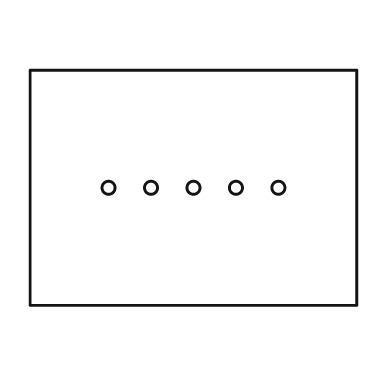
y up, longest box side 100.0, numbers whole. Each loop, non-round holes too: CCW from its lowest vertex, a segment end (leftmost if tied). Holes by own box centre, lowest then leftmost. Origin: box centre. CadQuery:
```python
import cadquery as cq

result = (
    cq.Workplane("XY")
    .moveTo(-50.0, -36.0)
    .lineTo(50.0, -36.0)
    .lineTo(50.0, 36.0)
    .lineTo(-50.0, 36.0)
    .close()
    .moveTo(-26.0, 0.0)
    .circle(2.0)
    .moveTo(-13.0, 0.0)
    .circle(2.0)
    .moveTo(0.0, 0.0)
    .circle(2.0)
    .moveTo(13.0, 0.0)
    .circle(2.0)
    .moveTo(26.0, 0.0)
    .circle(2.0)
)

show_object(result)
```